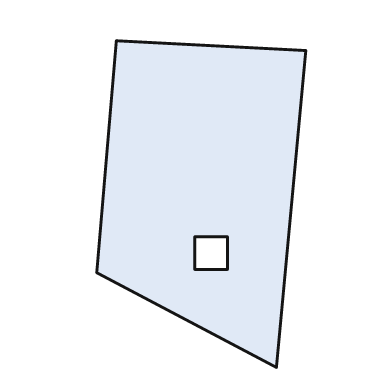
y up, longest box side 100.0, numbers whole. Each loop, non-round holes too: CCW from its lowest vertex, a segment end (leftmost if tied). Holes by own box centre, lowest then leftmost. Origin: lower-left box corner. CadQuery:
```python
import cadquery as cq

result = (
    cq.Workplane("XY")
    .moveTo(55.0, 0.0)
    .lineTo(64.0, 97.0)
    .lineTo(6.0, 100.0)
    .lineTo(0.0, 29.0)
    .close()
    .moveTo(30.0, 30.0)
    .lineTo(40.0, 30.0)
    .lineTo(40.0, 40.0)
    .lineTo(30.0, 40.0)
    .close()
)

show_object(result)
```